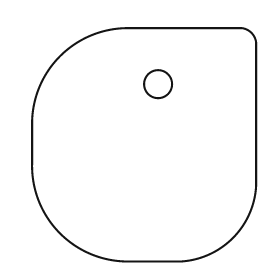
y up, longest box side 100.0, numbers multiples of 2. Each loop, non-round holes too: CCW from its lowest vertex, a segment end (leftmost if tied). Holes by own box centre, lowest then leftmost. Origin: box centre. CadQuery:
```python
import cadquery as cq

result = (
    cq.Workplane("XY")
    .moveTo(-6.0, -50.0)
    .lineTo(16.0, -50.0)
    .threePointArc((38.0, -40.0), (48.0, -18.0))
    .lineTo(48.0, 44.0)
    .threePointArc((46.0, 48.0), (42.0, 50.0))
    .lineTo(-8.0, 50.0)
    .threePointArc((-36.0, 38.0), (-48.0, 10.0))
    .lineTo(-48.0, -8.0)
    .threePointArc((-36.0, -38.0), (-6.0, -50.0))
    .close()
    .moveTo(6.0, 26.0)
    .circle(6.0)
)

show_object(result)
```